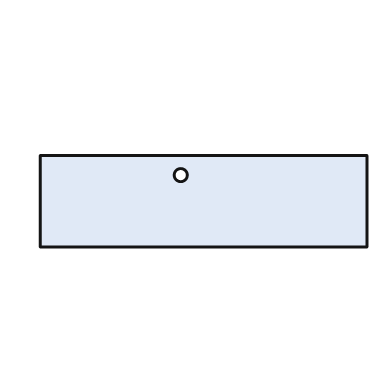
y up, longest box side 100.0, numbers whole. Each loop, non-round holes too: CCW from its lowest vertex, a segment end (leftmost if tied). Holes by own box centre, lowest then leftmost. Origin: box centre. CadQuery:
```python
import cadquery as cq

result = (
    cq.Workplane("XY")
    .moveTo(-50.0, -14.0)
    .lineTo(50.0, -14.0)
    .lineTo(50.0, 14.0)
    .lineTo(-50.0, 14.0)
    .close()
    .moveTo(-7.0, 8.0)
    .circle(2.0)
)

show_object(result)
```